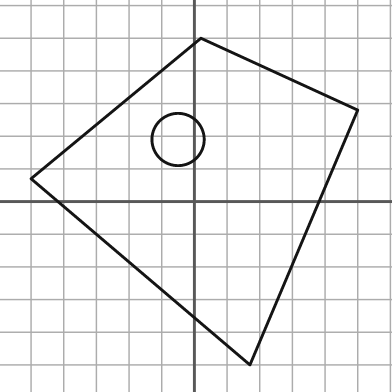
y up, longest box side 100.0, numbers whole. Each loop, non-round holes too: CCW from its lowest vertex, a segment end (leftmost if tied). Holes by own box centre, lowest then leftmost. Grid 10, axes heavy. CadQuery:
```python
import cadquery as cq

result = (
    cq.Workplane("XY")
    .moveTo(17.0, -50.0)
    .lineTo(50.0, 28.0)
    .lineTo(2.0, 50.0)
    .lineTo(-50.0, 7.0)
    .close()
    .moveTo(-5.0, 19.0)
    .circle(8.0)
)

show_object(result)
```